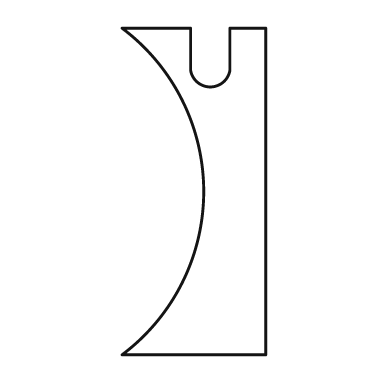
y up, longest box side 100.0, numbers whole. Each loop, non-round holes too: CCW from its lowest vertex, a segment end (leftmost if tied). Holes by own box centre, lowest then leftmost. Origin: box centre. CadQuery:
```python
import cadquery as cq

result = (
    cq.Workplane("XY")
    .moveTo(-22.0, -50.0)
    .lineTo(22.0, -50.0)
    .lineTo(22.0, 50.0)
    .lineTo(11.0, 50.0)
    .lineTo(11.0, 37.0)
    .threePointArc((5.0, 32.0), (-1.0, 37.0))
    .lineTo(-1.0, 50.0)
    .lineTo(-22.0, 50.0)
    .threePointArc((3.0, 0.0), (-22.0, -50.0))
    .close()
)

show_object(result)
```